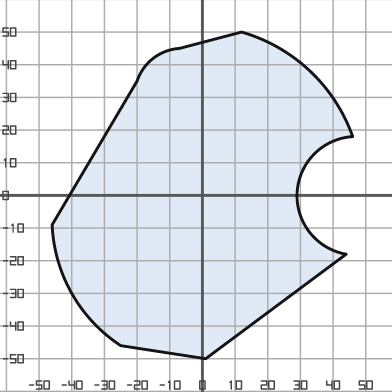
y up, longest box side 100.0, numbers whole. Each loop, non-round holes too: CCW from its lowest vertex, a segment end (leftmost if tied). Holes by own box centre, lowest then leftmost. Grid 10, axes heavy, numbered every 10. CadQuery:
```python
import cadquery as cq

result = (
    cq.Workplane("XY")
    .moveTo(1.0, -50.0)
    .lineTo(44.0, -18.0)
    .threePointArc((29.0, 1.0), (46.0, 18.0))
    .threePointArc((33.0, 38.0), (12.0, 50.0))
    .lineTo(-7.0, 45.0)
    .threePointArc((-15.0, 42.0), (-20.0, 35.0))
    .lineTo(-46.0, -9.0)
    .threePointArc((-40.0, -30.0), (-25.0, -46.0))
    .close()
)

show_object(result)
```